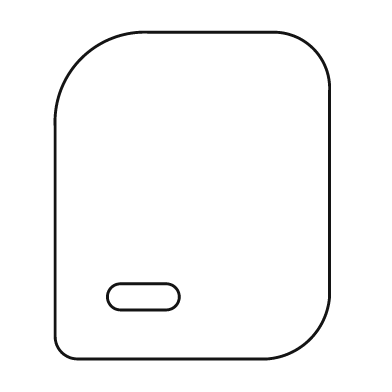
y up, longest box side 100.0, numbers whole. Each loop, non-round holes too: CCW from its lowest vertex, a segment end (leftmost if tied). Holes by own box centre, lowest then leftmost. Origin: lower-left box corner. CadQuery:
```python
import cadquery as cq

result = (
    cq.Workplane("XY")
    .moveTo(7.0, 0.0)
    .lineTo(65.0, 0.0)
    .threePointArc((78.0, 6.0), (84.0, 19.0))
    .lineTo(84.0, 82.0)
    .threePointArc((79.0, 95.0), (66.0, 100.0))
    .lineTo(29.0, 100.0)
    .threePointArc((8.0, 92.0), (0.0, 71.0))
    .lineTo(0.0, 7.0)
    .threePointArc((2.0, 2.0), (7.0, 0.0))
    .close()
    .moveTo(20.0, 15.0)
    .lineTo(34.0, 15.0)
    .threePointArc((38.0, 19.0), (34.0, 23.0))
    .lineTo(20.0, 23.0)
    .threePointArc((16.0, 19.0), (20.0, 15.0))
    .close()
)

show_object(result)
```